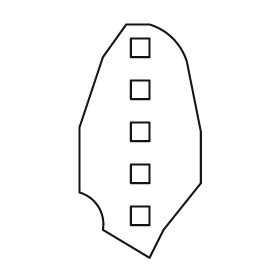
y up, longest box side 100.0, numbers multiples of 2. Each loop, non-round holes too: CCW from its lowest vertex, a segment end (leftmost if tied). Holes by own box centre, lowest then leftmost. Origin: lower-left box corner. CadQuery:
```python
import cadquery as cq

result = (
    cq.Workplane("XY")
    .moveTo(30.0, 0.0)
    .lineTo(36.0, 12.0)
    .lineTo(52.0, 32.0)
    .lineTo(52.0, 54.0)
    .lineTo(46.0, 84.0)
    .threePointArc((40.0, 94.0), (30.0, 100.0))
    .lineTo(20.0, 100.0)
    .lineTo(10.0, 86.0)
    .lineTo(0.0, 56.0)
    .lineTo(0.0, 28.0)
    .threePointArc((8.0, 22.0), (10.0, 12.0))
    .close()
    .moveTo(22.0, 14.0)
    .lineTo(30.0, 14.0)
    .lineTo(30.0, 22.0)
    .lineTo(22.0, 22.0)
    .close()
    .moveTo(22.0, 32.0)
    .lineTo(30.0, 32.0)
    .lineTo(30.0, 40.0)
    .lineTo(22.0, 40.0)
    .close()
    .moveTo(22.0, 50.0)
    .lineTo(30.0, 50.0)
    .lineTo(30.0, 58.0)
    .lineTo(22.0, 58.0)
    .close()
    .moveTo(22.0, 68.0)
    .lineTo(30.0, 68.0)
    .lineTo(30.0, 76.0)
    .lineTo(22.0, 76.0)
    .close()
    .moveTo(22.0, 86.0)
    .lineTo(30.0, 86.0)
    .lineTo(30.0, 94.0)
    .lineTo(22.0, 94.0)
    .close()
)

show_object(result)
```